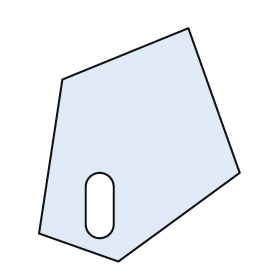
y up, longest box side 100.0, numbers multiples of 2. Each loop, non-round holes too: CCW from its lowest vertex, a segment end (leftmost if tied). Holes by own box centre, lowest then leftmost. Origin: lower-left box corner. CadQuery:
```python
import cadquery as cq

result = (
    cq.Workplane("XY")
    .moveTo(34.0, 0.0)
    .lineTo(86.0, 38.0)
    .lineTo(64.0, 100.0)
    .lineTo(10.0, 78.0)
    .lineTo(0.0, 12.0)
    .close()
    .moveTo(20.0, 16.0)
    .threePointArc((26.0, 10.0), (32.0, 16.0))
    .lineTo(32.0, 32.0)
    .threePointArc((26.0, 38.0), (20.0, 32.0))
    .close()
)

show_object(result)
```